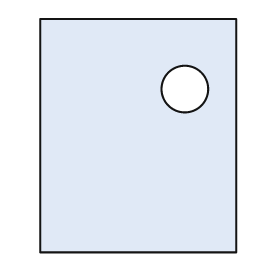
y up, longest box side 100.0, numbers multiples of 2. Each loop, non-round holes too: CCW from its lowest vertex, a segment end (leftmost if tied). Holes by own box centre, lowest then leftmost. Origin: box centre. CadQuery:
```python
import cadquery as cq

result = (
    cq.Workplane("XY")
    .moveTo(-42.0, -50.0)
    .lineTo(42.0, -50.0)
    .lineTo(42.0, 50.0)
    .lineTo(-42.0, 50.0)
    .close()
    .moveTo(20.0, 20.0)
    .circle(10.0)
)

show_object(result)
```